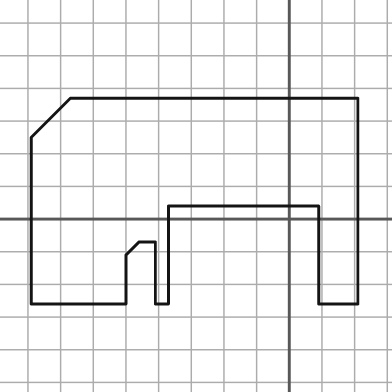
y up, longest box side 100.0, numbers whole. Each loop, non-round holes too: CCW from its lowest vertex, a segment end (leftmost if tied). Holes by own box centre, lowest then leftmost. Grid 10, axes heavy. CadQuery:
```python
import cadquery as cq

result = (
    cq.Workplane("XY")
    .moveTo(-79.0, -26.0)
    .lineTo(-50.0, -26.0)
    .lineTo(-50.0, -11.0)
    .lineTo(-46.0, -7.0)
    .lineTo(-41.0, -7.0)
    .lineTo(-41.0, -26.0)
    .lineTo(-37.0, -26.0)
    .lineTo(-37.0, 4.0)
    .lineTo(9.0, 4.0)
    .lineTo(9.0, -26.0)
    .lineTo(21.0, -26.0)
    .lineTo(21.0, 37.0)
    .lineTo(-67.0, 37.0)
    .lineTo(-79.0, 25.0)
    .close()
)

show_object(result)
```